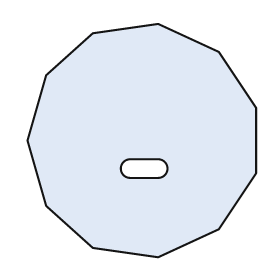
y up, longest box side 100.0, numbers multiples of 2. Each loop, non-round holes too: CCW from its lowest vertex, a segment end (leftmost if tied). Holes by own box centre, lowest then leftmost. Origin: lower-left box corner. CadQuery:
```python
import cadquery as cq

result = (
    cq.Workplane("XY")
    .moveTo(56.0, 0.0)
    .lineTo(82.0, 12.0)
    .lineTo(98.0, 36.0)
    .lineTo(98.0, 64.0)
    .lineTo(82.0, 88.0)
    .lineTo(56.0, 100.0)
    .lineTo(28.0, 96.0)
    .lineTo(8.0, 78.0)
    .lineTo(0.0, 50.0)
    .lineTo(8.0, 22.0)
    .lineTo(28.0, 4.0)
    .close()
    .moveTo(44.0, 34.0)
    .lineTo(56.0, 34.0)
    .threePointArc((60.0, 38.0), (56.0, 42.0))
    .lineTo(44.0, 42.0)
    .threePointArc((40.0, 38.0), (44.0, 34.0))
    .close()
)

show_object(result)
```